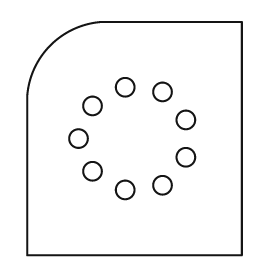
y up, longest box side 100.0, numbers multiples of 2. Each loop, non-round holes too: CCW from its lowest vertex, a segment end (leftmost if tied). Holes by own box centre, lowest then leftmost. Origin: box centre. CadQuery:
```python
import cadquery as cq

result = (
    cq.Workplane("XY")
    .moveTo(-46.0, -50.0)
    .lineTo(46.0, -50.0)
    .lineTo(46.0, 50.0)
    .lineTo(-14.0, 50.0)
    .threePointArc((-36.0, 40.0), (-46.0, 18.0))
    .close()
    .moveTo(-4.0, -22.0)
    .circle(4.0)
    .moveTo(12.0, -20.0)
    .circle(4.0)
    .moveTo(-18.0, -14.0)
    .circle(4.0)
    .moveTo(22.0, -8.0)
    .circle(4.0)
    .moveTo(-24.0, 0.0)
    .circle(4.0)
    .moveTo(22.0, 8.0)
    .circle(4.0)
    .moveTo(-18.0, 14.0)
    .circle(4.0)
    .moveTo(12.0, 20.0)
    .circle(4.0)
    .moveTo(-4.0, 22.0)
    .circle(4.0)
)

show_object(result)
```